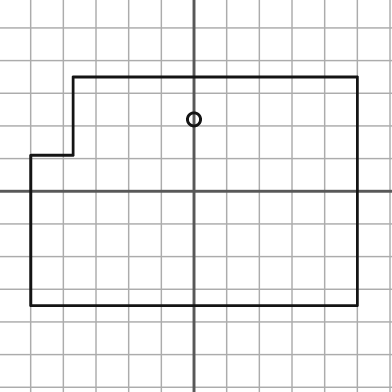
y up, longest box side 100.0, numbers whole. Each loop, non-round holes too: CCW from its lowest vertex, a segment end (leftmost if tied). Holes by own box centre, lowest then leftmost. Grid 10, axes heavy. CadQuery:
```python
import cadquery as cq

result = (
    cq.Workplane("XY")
    .moveTo(-50.0, -35.0)
    .lineTo(50.0, -35.0)
    .lineTo(50.0, 35.0)
    .lineTo(-37.0, 35.0)
    .lineTo(-37.0, 11.0)
    .lineTo(-50.0, 11.0)
    .close()
    .moveTo(0.0, 22.0)
    .circle(2.0)
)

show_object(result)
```